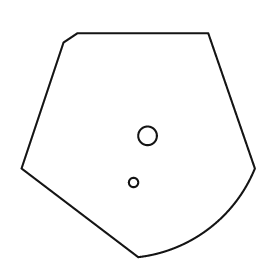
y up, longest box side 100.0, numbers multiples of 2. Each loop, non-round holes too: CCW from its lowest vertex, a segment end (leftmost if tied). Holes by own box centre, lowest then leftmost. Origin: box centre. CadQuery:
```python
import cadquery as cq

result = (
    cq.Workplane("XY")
    .moveTo(0.0, -48.0)
    .threePointArc((30.0, -36.0), (50.0, -10.0))
    .lineTo(30.0, 48.0)
    .lineTo(-26.0, 48.0)
    .lineTo(-32.0, 44.0)
    .lineTo(-50.0, -10.0)
    .close()
    .moveTo(-2.0, -16.0)
    .circle(2.0)
    .moveTo(4.0, 4.0)
    .circle(4.0)
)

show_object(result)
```